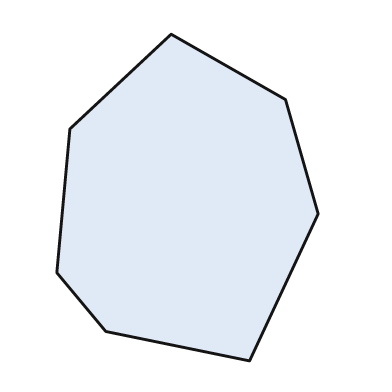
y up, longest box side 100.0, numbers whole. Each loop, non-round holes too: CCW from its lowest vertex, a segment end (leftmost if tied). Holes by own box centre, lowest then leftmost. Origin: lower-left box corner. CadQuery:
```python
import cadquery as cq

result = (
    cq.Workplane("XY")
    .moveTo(59.0, 0.0)
    .lineTo(80.0, 45.0)
    .lineTo(70.0, 80.0)
    .lineTo(35.0, 100.0)
    .lineTo(4.0, 71.0)
    .lineTo(0.0, 27.0)
    .lineTo(15.0, 9.0)
    .close()
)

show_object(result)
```